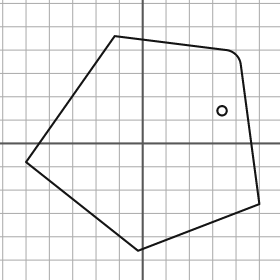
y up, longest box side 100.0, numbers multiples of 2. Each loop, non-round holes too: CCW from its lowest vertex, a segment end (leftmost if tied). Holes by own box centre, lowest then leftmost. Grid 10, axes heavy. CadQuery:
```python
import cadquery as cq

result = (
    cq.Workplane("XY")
    .moveTo(-2.0, -46.0)
    .lineTo(50.0, -26.0)
    .lineTo(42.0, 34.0)
    .threePointArc((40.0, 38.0), (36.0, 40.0))
    .lineTo(-12.0, 46.0)
    .lineTo(-50.0, -8.0)
    .close()
    .moveTo(34.0, 14.0)
    .circle(2.0)
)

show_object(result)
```